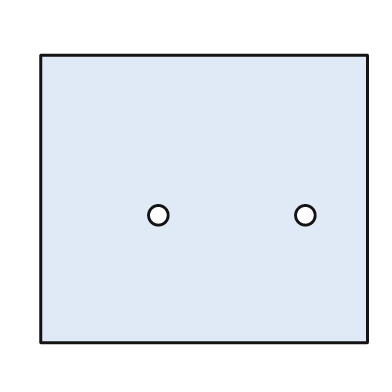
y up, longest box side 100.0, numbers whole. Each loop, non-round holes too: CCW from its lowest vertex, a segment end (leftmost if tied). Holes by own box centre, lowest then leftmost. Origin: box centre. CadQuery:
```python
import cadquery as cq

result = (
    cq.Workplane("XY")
    .moveTo(-50.0, -44.0)
    .lineTo(50.0, -44.0)
    .lineTo(50.0, 44.0)
    .lineTo(-50.0, 44.0)
    .close()
    .moveTo(-14.0, -5.0)
    .circle(3.0)
    .moveTo(31.0, -5.0)
    .circle(3.0)
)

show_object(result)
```